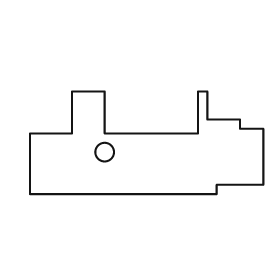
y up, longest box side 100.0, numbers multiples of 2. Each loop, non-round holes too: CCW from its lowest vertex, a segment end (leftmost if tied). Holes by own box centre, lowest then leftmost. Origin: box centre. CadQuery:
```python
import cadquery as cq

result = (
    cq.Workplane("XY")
    .moveTo(-50.0, -22.0)
    .lineTo(30.0, -22.0)
    .lineTo(30.0, -18.0)
    .lineTo(50.0, -18.0)
    .lineTo(50.0, 6.0)
    .lineTo(40.0, 6.0)
    .lineTo(40.0, 10.0)
    .lineTo(26.0, 10.0)
    .lineTo(26.0, 22.0)
    .lineTo(22.0, 22.0)
    .lineTo(22.0, 4.0)
    .lineTo(-18.0, 4.0)
    .lineTo(-18.0, 22.0)
    .lineTo(-32.0, 22.0)
    .lineTo(-32.0, 4.0)
    .lineTo(-50.0, 4.0)
    .close()
    .moveTo(-18.0, -4.0)
    .circle(4.0)
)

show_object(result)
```